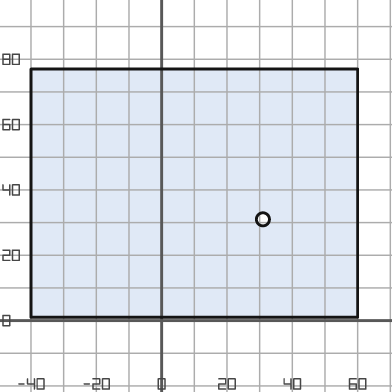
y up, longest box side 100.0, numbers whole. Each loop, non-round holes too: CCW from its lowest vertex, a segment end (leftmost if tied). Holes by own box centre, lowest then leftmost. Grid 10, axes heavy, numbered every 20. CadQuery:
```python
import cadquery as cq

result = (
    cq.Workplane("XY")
    .moveTo(-40.0, 1.0)
    .lineTo(60.0, 1.0)
    .lineTo(60.0, 77.0)
    .lineTo(-40.0, 77.0)
    .close()
    .moveTo(31.0, 31.0)
    .circle(2.0)
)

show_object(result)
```